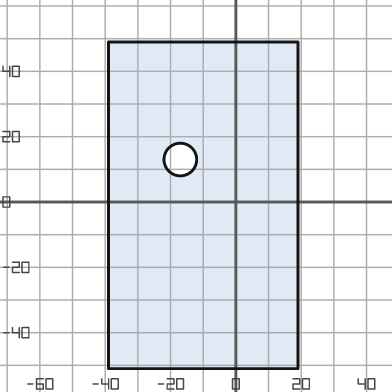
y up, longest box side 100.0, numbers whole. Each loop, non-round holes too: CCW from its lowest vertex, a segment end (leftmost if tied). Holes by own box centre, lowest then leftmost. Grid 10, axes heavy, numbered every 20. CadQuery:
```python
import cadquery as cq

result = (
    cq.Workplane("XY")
    .moveTo(-39.0, -51.0)
    .lineTo(19.0, -51.0)
    .lineTo(19.0, 49.0)
    .lineTo(-39.0, 49.0)
    .close()
    .moveTo(-17.0, 13.0)
    .circle(5.0)
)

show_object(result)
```